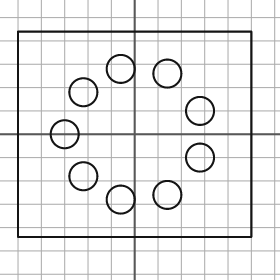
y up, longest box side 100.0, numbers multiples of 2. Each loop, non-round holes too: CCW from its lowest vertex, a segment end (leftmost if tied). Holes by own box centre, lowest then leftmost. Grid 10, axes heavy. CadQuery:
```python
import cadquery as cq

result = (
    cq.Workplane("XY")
    .moveTo(-50.0, -44.0)
    .lineTo(50.0, -44.0)
    .lineTo(50.0, 44.0)
    .lineTo(-50.0, 44.0)
    .close()
    .moveTo(-6.0, -28.0)
    .circle(6.0)
    .moveTo(14.0, -26.0)
    .circle(6.0)
    .moveTo(-22.0, -18.0)
    .circle(6.0)
    .moveTo(28.0, -10.0)
    .circle(6.0)
    .moveTo(-30.0, 0.0)
    .circle(6.0)
    .moveTo(28.0, 10.0)
    .circle(6.0)
    .moveTo(-22.0, 18.0)
    .circle(6.0)
    .moveTo(14.0, 26.0)
    .circle(6.0)
    .moveTo(-6.0, 28.0)
    .circle(6.0)
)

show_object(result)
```